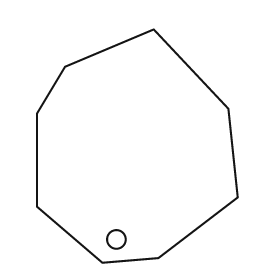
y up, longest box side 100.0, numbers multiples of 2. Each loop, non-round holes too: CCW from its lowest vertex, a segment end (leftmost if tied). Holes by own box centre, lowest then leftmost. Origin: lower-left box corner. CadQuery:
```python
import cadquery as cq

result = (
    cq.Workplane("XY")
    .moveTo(28.0, 0.0)
    .lineTo(52.0, 2.0)
    .lineTo(86.0, 28.0)
    .lineTo(82.0, 66.0)
    .lineTo(50.0, 100.0)
    .lineTo(12.0, 84.0)
    .lineTo(0.0, 64.0)
    .lineTo(0.0, 24.0)
    .close()
    .moveTo(34.0, 10.0)
    .circle(4.0)
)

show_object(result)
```